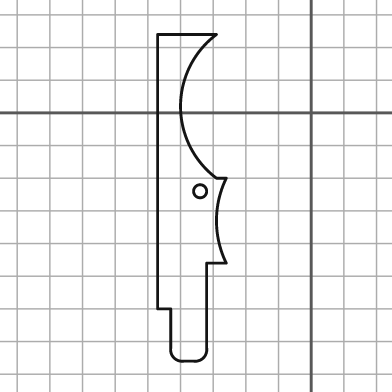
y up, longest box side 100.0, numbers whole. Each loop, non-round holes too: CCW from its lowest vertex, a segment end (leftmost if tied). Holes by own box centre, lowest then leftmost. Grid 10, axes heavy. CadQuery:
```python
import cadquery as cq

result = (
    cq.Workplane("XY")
    .moveTo(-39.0, -76.0)
    .lineTo(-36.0, -76.0)
    .threePointArc((-33.0, -75.0), (-32.0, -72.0))
    .lineTo(-32.0, -46.0)
    .lineTo(-26.0, -46.0)
    .threePointArc((-29.0, -33.0), (-26.0, -20.0))
    .lineTo(-29.0, -20.0)
    .threePointArc((-40.0, 2.0), (-29.0, 24.0))
    .lineTo(-47.0, 24.0)
    .lineTo(-47.0, -60.0)
    .lineTo(-43.0, -60.0)
    .lineTo(-43.0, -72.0)
    .threePointArc((-42.0, -75.0), (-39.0, -76.0))
    .close()
    .moveTo(-34.0, -24.0)
    .circle(2.0)
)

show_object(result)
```